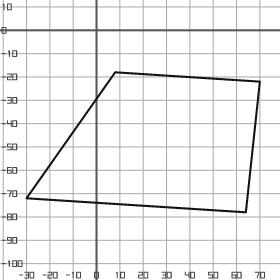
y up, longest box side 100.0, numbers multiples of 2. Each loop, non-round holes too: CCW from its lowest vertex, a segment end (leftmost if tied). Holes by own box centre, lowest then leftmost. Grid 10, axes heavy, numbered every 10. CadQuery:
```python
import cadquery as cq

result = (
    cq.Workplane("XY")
    .moveTo(64.0, -78.0)
    .lineTo(70.0, -22.0)
    .lineTo(8.0, -18.0)
    .lineTo(-30.0, -72.0)
    .close()
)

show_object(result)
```